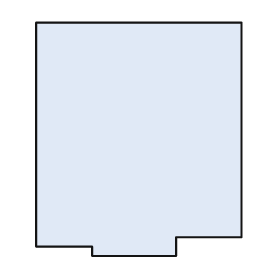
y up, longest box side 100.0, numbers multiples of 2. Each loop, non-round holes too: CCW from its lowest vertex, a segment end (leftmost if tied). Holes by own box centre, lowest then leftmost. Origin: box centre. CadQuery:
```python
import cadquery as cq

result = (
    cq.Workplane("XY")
    .moveTo(-20.0, -50.0)
    .lineTo(16.0, -50.0)
    .lineTo(16.0, -42.0)
    .lineTo(44.0, -42.0)
    .lineTo(44.0, 50.0)
    .lineTo(-44.0, 50.0)
    .lineTo(-44.0, -46.0)
    .lineTo(-20.0, -46.0)
    .close()
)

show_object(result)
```